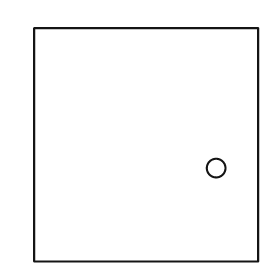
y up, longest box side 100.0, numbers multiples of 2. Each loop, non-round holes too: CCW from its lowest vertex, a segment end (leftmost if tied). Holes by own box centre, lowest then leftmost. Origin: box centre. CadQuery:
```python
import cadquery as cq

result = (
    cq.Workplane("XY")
    .moveTo(-48.0, -50.0)
    .lineTo(48.0, -50.0)
    .lineTo(48.0, 50.0)
    .lineTo(-48.0, 50.0)
    .close()
    .moveTo(30.0, -10.0)
    .circle(4.0)
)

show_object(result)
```